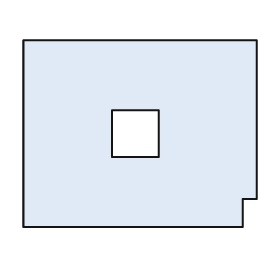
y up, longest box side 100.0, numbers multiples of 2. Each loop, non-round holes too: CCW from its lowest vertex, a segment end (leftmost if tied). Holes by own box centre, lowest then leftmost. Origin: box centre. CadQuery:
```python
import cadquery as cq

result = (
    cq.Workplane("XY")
    .moveTo(-50.0, -40.0)
    .lineTo(44.0, -40.0)
    .lineTo(44.0, -28.0)
    .lineTo(50.0, -28.0)
    .lineTo(50.0, 40.0)
    .lineTo(-50.0, 40.0)
    .close()
    .moveTo(-12.0, -10.0)
    .lineTo(8.0, -10.0)
    .lineTo(8.0, 10.0)
    .lineTo(-12.0, 10.0)
    .close()
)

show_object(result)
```